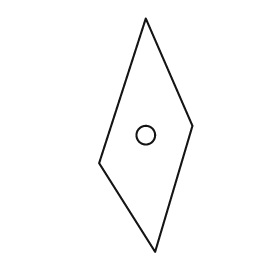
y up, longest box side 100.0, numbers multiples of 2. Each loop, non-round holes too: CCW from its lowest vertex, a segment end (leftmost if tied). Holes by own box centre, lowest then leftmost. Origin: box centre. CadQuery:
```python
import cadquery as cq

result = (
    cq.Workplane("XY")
    .moveTo(4.0, -50.0)
    .lineTo(20.0, 4.0)
    .lineTo(0.0, 50.0)
    .lineTo(-20.0, -12.0)
    .close()
    .moveTo(0.0, 0.0)
    .circle(4.0)
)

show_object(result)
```